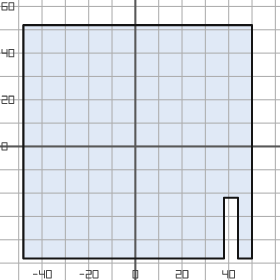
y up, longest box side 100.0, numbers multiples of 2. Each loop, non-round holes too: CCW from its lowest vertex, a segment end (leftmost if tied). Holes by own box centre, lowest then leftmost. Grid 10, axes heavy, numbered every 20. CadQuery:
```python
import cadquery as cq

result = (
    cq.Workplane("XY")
    .moveTo(-48.0, -48.0)
    .lineTo(38.0, -48.0)
    .lineTo(38.0, -22.0)
    .lineTo(44.0, -22.0)
    .lineTo(44.0, -48.0)
    .lineTo(50.0, -48.0)
    .lineTo(50.0, 52.0)
    .lineTo(-48.0, 52.0)
    .close()
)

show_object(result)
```